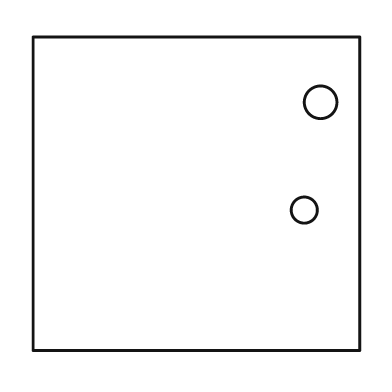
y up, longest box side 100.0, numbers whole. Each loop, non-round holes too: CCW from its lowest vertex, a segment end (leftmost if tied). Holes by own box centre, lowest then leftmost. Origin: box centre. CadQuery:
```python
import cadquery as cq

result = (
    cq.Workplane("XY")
    .moveTo(-50.0, -48.0)
    .lineTo(50.0, -48.0)
    .lineTo(50.0, 48.0)
    .lineTo(-50.0, 48.0)
    .close()
    .moveTo(33.0, -5.0)
    .circle(4.0)
    .moveTo(38.0, 28.0)
    .circle(5.0)
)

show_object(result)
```